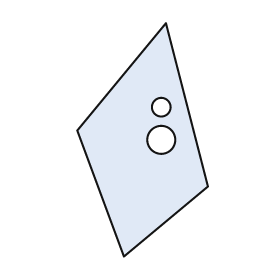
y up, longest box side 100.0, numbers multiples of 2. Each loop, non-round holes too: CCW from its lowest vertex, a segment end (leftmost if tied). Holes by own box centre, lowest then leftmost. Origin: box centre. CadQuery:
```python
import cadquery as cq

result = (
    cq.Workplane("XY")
    .moveTo(-8.0, -50.0)
    .lineTo(28.0, -20.0)
    .lineTo(10.0, 50.0)
    .lineTo(-28.0, 4.0)
    .close()
    .moveTo(8.0, 0.0)
    .circle(6.0)
    .moveTo(8.0, 14.0)
    .circle(4.0)
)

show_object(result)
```